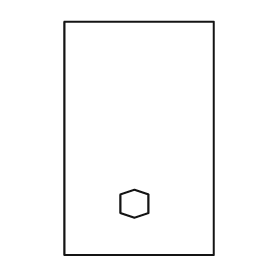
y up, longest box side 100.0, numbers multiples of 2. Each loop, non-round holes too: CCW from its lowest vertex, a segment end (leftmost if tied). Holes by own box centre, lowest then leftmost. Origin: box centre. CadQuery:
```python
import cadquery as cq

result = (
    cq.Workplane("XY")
    .moveTo(-32.0, -50.0)
    .lineTo(32.0, -50.0)
    .lineTo(32.0, 50.0)
    .lineTo(-32.0, 50.0)
    .close()
    .moveTo(-2.0, -34.0)
    .lineTo(4.0, -32.0)
    .lineTo(4.0, -24.0)
    .lineTo(-2.0, -22.0)
    .lineTo(-8.0, -24.0)
    .lineTo(-8.0, -32.0)
    .close()
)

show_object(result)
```